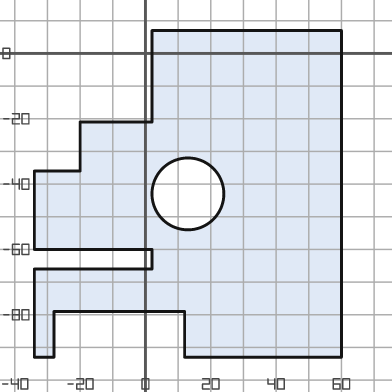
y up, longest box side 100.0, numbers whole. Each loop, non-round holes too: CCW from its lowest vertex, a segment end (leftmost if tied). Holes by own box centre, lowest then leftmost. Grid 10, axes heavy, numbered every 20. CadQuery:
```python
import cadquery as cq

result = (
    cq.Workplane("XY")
    .moveTo(-34.0, -93.0)
    .lineTo(-28.0, -93.0)
    .lineTo(-28.0, -79.0)
    .lineTo(12.0, -79.0)
    .lineTo(12.0, -93.0)
    .lineTo(60.0, -93.0)
    .lineTo(60.0, 7.0)
    .lineTo(2.0, 7.0)
    .lineTo(2.0, -21.0)
    .lineTo(-20.0, -21.0)
    .lineTo(-20.0, -36.0)
    .lineTo(-34.0, -36.0)
    .lineTo(-34.0, -60.0)
    .lineTo(2.0, -60.0)
    .lineTo(2.0, -66.0)
    .lineTo(-34.0, -66.0)
    .close()
    .moveTo(13.0, -43.0)
    .circle(11.0)
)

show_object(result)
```